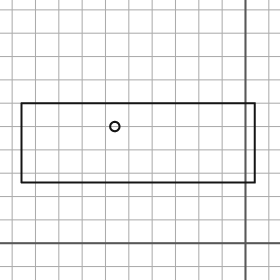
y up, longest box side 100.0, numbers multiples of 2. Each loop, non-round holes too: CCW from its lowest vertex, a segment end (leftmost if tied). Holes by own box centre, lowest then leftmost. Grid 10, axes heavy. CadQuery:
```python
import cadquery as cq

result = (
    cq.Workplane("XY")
    .moveTo(-96.0, 26.0)
    .lineTo(4.0, 26.0)
    .lineTo(4.0, 60.0)
    .lineTo(-96.0, 60.0)
    .close()
    .moveTo(-56.0, 50.0)
    .circle(2.0)
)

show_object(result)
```